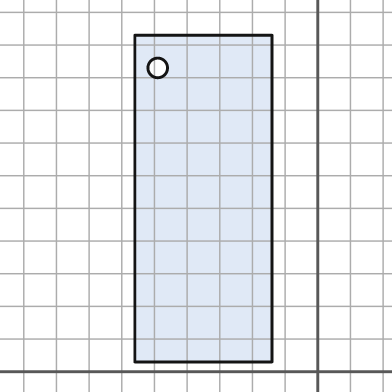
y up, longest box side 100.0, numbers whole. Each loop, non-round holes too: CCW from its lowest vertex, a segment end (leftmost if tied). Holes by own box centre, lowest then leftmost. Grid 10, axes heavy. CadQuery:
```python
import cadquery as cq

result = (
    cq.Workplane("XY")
    .moveTo(-56.0, 3.0)
    .lineTo(-14.0, 3.0)
    .lineTo(-14.0, 103.0)
    .lineTo(-56.0, 103.0)
    .close()
    .moveTo(-49.0, 93.0)
    .circle(3.0)
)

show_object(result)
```